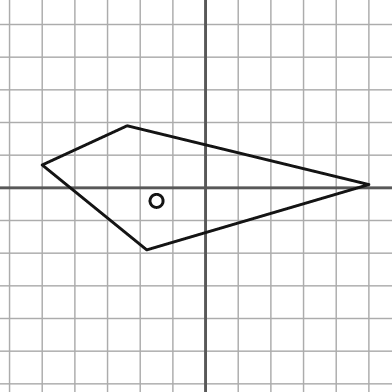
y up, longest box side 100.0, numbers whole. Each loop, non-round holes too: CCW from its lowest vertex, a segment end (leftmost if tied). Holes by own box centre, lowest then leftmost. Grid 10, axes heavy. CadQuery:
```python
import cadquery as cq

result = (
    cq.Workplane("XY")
    .moveTo(-18.0, -19.0)
    .lineTo(50.0, 1.0)
    .lineTo(-24.0, 19.0)
    .lineTo(-50.0, 7.0)
    .close()
    .moveTo(-15.0, -4.0)
    .circle(2.0)
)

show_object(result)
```